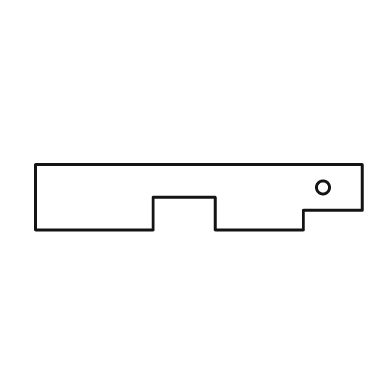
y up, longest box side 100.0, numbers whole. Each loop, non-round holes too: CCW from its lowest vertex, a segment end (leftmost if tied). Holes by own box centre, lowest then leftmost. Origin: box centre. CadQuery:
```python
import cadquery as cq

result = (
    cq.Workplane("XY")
    .moveTo(-50.0, -10.0)
    .lineTo(-14.0, -10.0)
    .lineTo(-14.0, 0.0)
    .lineTo(5.0, 0.0)
    .lineTo(5.0, -10.0)
    .lineTo(32.0, -10.0)
    .lineTo(32.0, -4.0)
    .lineTo(50.0, -4.0)
    .lineTo(50.0, 10.0)
    .lineTo(-50.0, 10.0)
    .close()
    .moveTo(38.0, 3.0)
    .circle(2.0)
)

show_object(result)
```